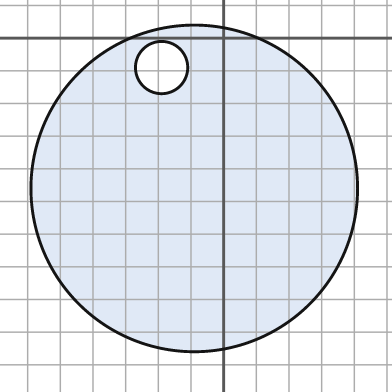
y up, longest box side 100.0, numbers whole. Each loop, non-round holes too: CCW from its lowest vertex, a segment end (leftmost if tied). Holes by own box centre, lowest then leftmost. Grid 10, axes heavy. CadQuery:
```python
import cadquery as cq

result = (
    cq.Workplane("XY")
    .moveTo(-9.0, -46.0)
    .circle(50.0)
    .moveTo(-19.0, -9.0)
    .circle(8.0)
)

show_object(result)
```